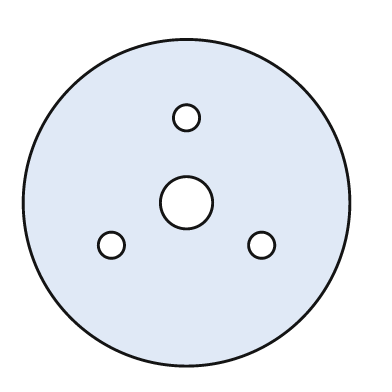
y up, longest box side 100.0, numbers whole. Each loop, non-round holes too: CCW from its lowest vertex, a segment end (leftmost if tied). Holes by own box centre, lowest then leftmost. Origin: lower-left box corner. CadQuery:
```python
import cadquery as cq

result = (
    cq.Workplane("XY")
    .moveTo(50.0, 50.0)
    .circle(50.0)
    .moveTo(27.0, 37.0)
    .circle(4.0)
    .moveTo(73.0, 37.0)
    .circle(4.0)
    .moveTo(50.0, 50.0)
    .circle(8.0)
    .moveTo(50.0, 76.0)
    .circle(4.0)
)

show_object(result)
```